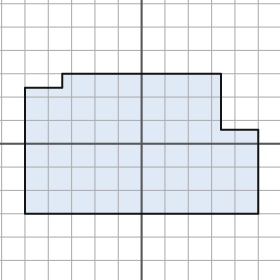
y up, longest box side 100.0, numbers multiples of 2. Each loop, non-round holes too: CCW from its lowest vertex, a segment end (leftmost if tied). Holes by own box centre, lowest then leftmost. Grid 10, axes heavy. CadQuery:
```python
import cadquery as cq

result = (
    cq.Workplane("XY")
    .moveTo(-50.0, -30.0)
    .lineTo(50.0, -30.0)
    .lineTo(50.0, 6.0)
    .lineTo(34.0, 6.0)
    .lineTo(34.0, 30.0)
    .lineTo(-34.0, 30.0)
    .lineTo(-34.0, 24.0)
    .lineTo(-50.0, 24.0)
    .close()
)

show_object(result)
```